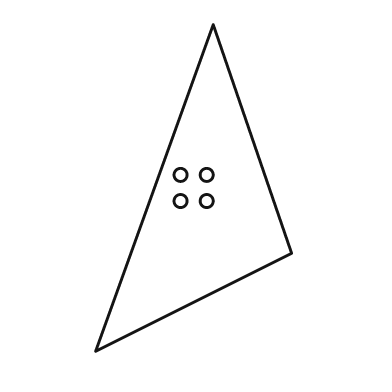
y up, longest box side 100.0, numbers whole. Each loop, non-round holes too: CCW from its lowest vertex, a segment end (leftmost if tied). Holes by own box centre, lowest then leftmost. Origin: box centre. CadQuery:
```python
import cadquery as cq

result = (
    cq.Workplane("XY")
    .moveTo(-30.0, -50.0)
    .lineTo(30.0, -20.0)
    .lineTo(6.0, 50.0)
    .close()
    .moveTo(-4.0, -4.0)
    .circle(2.0)
    .moveTo(4.0, -4.0)
    .circle(2.0)
    .moveTo(-4.0, 4.0)
    .circle(2.0)
    .moveTo(4.0, 4.0)
    .circle(2.0)
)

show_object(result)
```